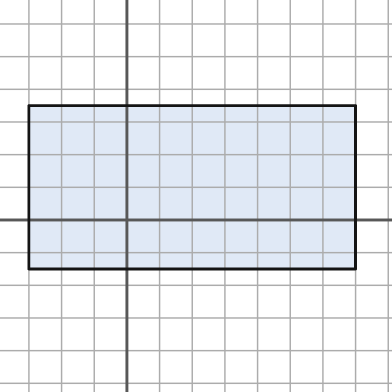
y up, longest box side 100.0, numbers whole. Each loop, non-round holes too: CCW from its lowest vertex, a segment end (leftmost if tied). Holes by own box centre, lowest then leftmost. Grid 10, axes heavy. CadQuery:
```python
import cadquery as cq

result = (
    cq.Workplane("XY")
    .moveTo(-30.0, -15.0)
    .lineTo(70.0, -15.0)
    .lineTo(70.0, 35.0)
    .lineTo(-30.0, 35.0)
    .close()
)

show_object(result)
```